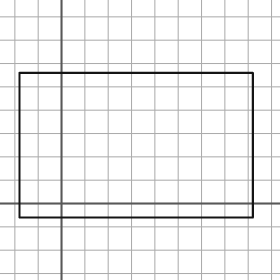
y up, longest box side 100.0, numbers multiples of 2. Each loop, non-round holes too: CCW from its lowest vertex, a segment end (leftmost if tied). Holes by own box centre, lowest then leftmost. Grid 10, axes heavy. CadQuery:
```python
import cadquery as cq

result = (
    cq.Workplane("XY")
    .moveTo(-18.0, -6.0)
    .lineTo(82.0, -6.0)
    .lineTo(82.0, 56.0)
    .lineTo(-18.0, 56.0)
    .close()
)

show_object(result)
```